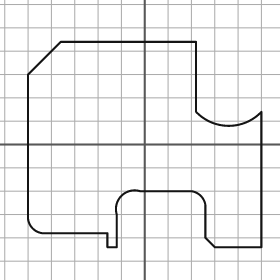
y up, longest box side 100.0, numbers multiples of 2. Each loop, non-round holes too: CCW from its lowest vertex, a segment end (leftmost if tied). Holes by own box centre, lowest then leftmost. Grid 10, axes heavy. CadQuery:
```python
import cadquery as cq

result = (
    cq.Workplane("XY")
    .moveTo(-16.0, -44.0)
    .lineTo(-12.0, -44.0)
    .lineTo(-12.0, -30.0)
    .threePointArc((-10.0, -22.0), (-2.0, -20.0))
    .lineTo(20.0, -20.0)
    .threePointArc((24.0, -22.0), (26.0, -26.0))
    .lineTo(26.0, -40.0)
    .lineTo(30.0, -44.0)
    .lineTo(50.0, -44.0)
    .lineTo(50.0, 14.0)
    .threePointArc((36.0, 8.0), (22.0, 14.0))
    .lineTo(22.0, 44.0)
    .lineTo(-36.0, 44.0)
    .lineTo(-50.0, 30.0)
    .lineTo(-50.0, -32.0)
    .threePointArc((-48.0, -36.0), (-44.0, -38.0))
    .lineTo(-16.0, -38.0)
    .close()
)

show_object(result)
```